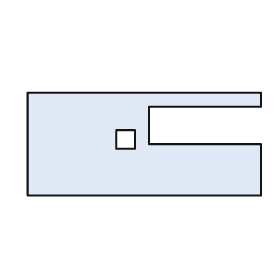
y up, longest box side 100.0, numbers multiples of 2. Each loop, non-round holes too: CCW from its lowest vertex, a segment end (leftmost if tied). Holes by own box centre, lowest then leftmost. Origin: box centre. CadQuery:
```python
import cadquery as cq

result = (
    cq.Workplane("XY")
    .moveTo(-50.0, -22.0)
    .lineTo(50.0, -22.0)
    .lineTo(50.0, 0.0)
    .lineTo(2.0, 0.0)
    .lineTo(2.0, 16.0)
    .lineTo(50.0, 16.0)
    .lineTo(50.0, 22.0)
    .lineTo(-50.0, 22.0)
    .close()
    .moveTo(-12.0, -2.0)
    .lineTo(-4.0, -2.0)
    .lineTo(-4.0, 6.0)
    .lineTo(-12.0, 6.0)
    .close()
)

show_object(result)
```